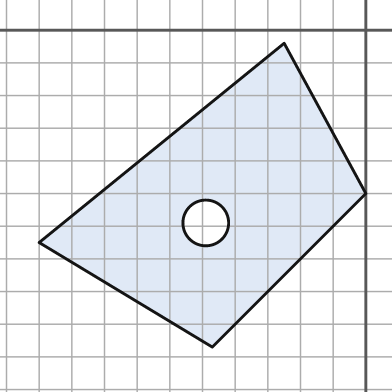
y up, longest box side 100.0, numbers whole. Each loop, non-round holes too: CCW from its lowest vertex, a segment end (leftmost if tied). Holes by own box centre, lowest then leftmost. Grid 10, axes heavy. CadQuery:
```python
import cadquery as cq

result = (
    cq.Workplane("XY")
    .moveTo(-47.0, -97.0)
    .lineTo(0.0, -50.0)
    .lineTo(-25.0, -4.0)
    .lineTo(-100.0, -65.0)
    .close()
    .moveTo(-49.0, -59.0)
    .circle(7.0)
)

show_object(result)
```